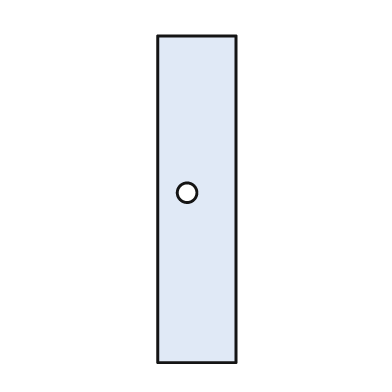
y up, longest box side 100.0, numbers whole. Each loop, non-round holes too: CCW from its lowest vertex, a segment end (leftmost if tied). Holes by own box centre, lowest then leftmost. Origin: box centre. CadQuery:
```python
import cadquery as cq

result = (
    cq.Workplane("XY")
    .moveTo(-12.0, -50.0)
    .lineTo(12.0, -50.0)
    .lineTo(12.0, 50.0)
    .lineTo(-12.0, 50.0)
    .close()
    .moveTo(-3.0, 2.0)
    .circle(3.0)
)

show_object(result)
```